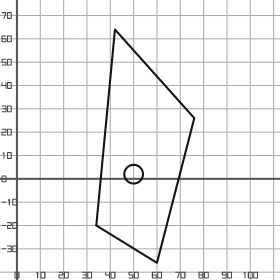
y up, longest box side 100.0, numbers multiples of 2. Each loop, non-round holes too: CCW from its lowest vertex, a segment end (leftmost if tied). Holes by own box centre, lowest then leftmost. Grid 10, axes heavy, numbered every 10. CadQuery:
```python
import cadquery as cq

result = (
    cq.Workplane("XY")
    .moveTo(60.0, -36.0)
    .lineTo(76.0, 26.0)
    .lineTo(42.0, 64.0)
    .lineTo(34.0, -20.0)
    .close()
    .moveTo(50.0, 2.0)
    .circle(4.0)
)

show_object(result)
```